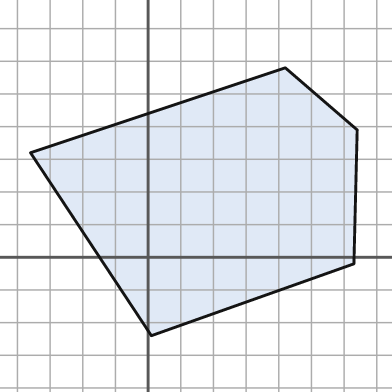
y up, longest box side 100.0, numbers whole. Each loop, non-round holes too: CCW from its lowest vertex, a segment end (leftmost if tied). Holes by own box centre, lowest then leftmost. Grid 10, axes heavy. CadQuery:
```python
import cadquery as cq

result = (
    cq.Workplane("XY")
    .moveTo(1.0, -24.0)
    .lineTo(63.0, -2.0)
    .lineTo(64.0, 39.0)
    .lineTo(42.0, 58.0)
    .lineTo(-36.0, 32.0)
    .close()
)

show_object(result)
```